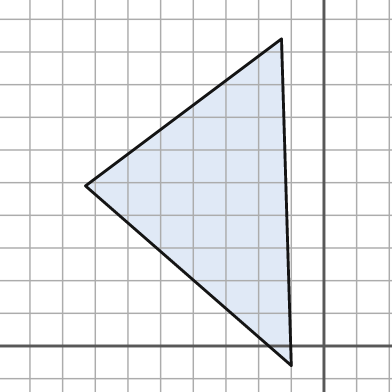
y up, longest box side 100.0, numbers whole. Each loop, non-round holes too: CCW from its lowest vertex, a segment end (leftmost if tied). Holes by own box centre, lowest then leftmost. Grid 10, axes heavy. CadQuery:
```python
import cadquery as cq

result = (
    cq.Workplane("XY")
    .moveTo(-10.0, -6.0)
    .lineTo(-13.0, 94.0)
    .lineTo(-73.0, 49.0)
    .close()
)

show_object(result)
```